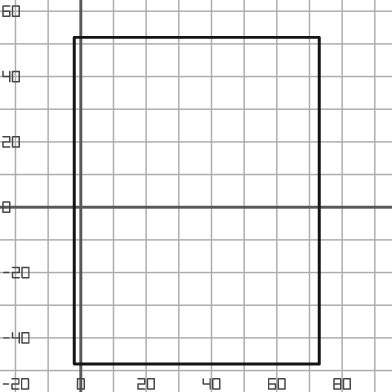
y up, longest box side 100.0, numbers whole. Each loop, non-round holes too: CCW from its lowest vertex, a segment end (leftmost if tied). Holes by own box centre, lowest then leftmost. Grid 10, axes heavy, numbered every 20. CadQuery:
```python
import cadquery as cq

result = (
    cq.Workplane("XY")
    .moveTo(-2.0, -48.0)
    .lineTo(73.0, -48.0)
    .lineTo(73.0, 52.0)
    .lineTo(-2.0, 52.0)
    .close()
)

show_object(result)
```